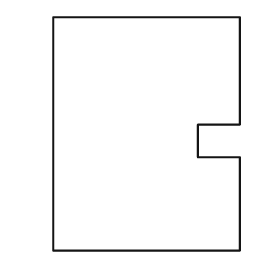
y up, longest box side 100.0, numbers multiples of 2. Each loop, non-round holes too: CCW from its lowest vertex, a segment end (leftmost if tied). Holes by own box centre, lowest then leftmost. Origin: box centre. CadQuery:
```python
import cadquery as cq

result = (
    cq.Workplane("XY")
    .moveTo(-40.0, -50.0)
    .lineTo(40.0, -50.0)
    .lineTo(40.0, -10.0)
    .lineTo(22.0, -10.0)
    .lineTo(22.0, 4.0)
    .lineTo(40.0, 4.0)
    .lineTo(40.0, 50.0)
    .lineTo(-40.0, 50.0)
    .close()
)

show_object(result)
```